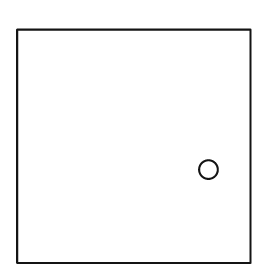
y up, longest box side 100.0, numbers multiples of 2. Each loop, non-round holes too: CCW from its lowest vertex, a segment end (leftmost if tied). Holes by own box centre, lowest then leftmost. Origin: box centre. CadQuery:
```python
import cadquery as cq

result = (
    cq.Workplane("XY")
    .moveTo(-50.0, -50.0)
    .lineTo(50.0, -50.0)
    .lineTo(50.0, 50.0)
    .lineTo(-50.0, 50.0)
    .close()
    .moveTo(32.0, -10.0)
    .circle(4.0)
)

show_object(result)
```